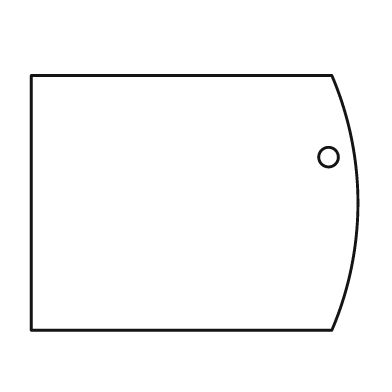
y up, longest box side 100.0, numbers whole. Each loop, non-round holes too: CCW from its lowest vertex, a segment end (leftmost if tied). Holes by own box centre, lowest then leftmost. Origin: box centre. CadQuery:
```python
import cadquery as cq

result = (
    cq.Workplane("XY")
    .moveTo(-50.0, -39.0)
    .lineTo(42.0, -39.0)
    .threePointArc((50.0, 0.0), (42.0, 39.0))
    .lineTo(-50.0, 39.0)
    .close()
    .moveTo(41.0, 14.0)
    .circle(3.0)
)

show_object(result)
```